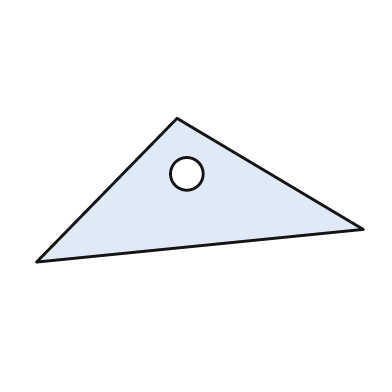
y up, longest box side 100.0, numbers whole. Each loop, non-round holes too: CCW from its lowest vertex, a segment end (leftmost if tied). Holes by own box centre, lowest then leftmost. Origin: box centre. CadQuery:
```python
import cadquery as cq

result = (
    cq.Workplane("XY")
    .moveTo(-50.0, -22.0)
    .lineTo(50.0, -12.0)
    .lineTo(-7.0, 22.0)
    .close()
    .moveTo(-4.0, 5.0)
    .circle(5.0)
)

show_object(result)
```